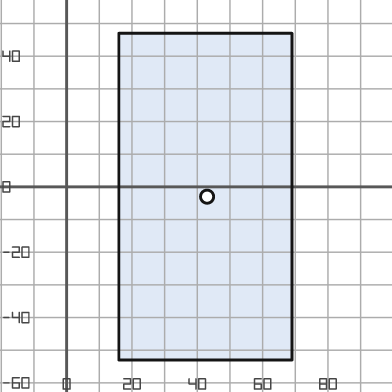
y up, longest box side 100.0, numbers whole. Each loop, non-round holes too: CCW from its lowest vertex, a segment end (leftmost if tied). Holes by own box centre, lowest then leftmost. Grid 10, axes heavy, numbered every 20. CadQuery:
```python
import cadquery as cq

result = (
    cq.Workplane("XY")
    .moveTo(16.0, -53.0)
    .lineTo(69.0, -53.0)
    .lineTo(69.0, 47.0)
    .lineTo(16.0, 47.0)
    .close()
    .moveTo(43.0, -3.0)
    .circle(2.0)
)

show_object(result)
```